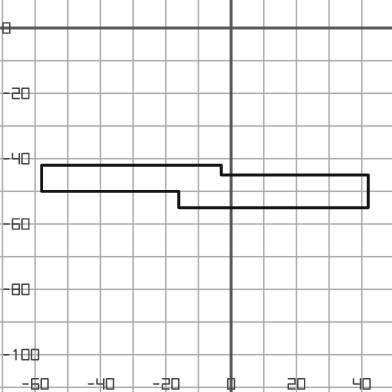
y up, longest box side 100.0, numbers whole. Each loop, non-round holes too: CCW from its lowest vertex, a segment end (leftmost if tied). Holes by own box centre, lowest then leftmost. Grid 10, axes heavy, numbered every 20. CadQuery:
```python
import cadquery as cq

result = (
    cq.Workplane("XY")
    .moveTo(-16.0, -55.0)
    .lineTo(42.0, -55.0)
    .lineTo(42.0, -45.0)
    .lineTo(-3.0, -45.0)
    .lineTo(-3.0, -42.0)
    .lineTo(-58.0, -42.0)
    .lineTo(-58.0, -50.0)
    .lineTo(-16.0, -50.0)
    .close()
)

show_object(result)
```